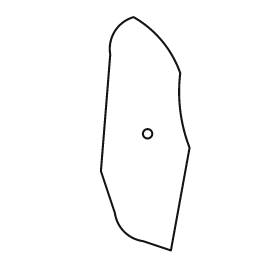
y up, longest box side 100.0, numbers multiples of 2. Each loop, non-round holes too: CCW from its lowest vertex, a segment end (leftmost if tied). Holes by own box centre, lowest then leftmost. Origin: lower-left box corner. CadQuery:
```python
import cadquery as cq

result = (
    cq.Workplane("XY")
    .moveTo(30.0, 0.0)
    .lineTo(38.0, 44.0)
    .threePointArc((34.0, 60.0), (34.0, 76.0))
    .threePointArc((26.0, 90.0), (14.0, 100.0))
    .threePointArc((6.0, 94.0), (4.0, 84.0))
    .lineTo(0.0, 34.0)
    .lineTo(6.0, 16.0)
    .threePointArc((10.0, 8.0), (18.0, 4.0))
    .close()
    .moveTo(20.0, 50.0)
    .circle(2.0)
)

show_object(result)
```